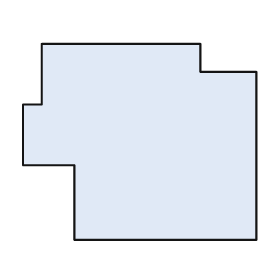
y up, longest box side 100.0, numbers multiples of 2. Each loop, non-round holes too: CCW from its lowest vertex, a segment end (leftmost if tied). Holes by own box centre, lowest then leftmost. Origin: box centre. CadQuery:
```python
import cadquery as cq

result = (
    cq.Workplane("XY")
    .moveTo(-28.0, -42.0)
    .lineTo(50.0, -42.0)
    .lineTo(50.0, 30.0)
    .lineTo(26.0, 30.0)
    .lineTo(26.0, 42.0)
    .lineTo(-42.0, 42.0)
    .lineTo(-42.0, 16.0)
    .lineTo(-50.0, 16.0)
    .lineTo(-50.0, -10.0)
    .lineTo(-28.0, -10.0)
    .close()
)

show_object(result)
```